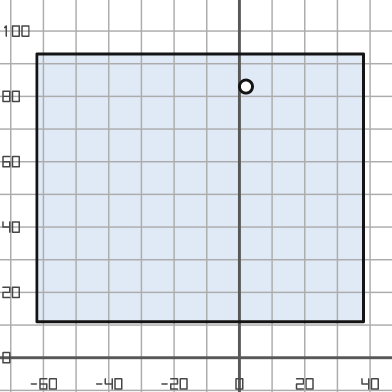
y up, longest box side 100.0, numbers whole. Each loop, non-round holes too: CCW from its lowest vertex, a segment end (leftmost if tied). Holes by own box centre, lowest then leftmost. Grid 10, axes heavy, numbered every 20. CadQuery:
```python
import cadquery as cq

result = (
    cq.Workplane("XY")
    .moveTo(-62.0, 11.0)
    .lineTo(38.0, 11.0)
    .lineTo(38.0, 93.0)
    .lineTo(-62.0, 93.0)
    .close()
    .moveTo(2.0, 83.0)
    .circle(2.0)
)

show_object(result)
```